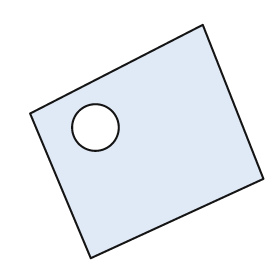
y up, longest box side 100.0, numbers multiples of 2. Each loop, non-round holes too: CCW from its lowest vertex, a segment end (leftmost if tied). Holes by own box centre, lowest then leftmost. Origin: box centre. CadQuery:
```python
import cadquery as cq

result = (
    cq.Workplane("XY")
    .moveTo(-24.0, -50.0)
    .lineTo(50.0, -16.0)
    .lineTo(24.0, 50.0)
    .lineTo(-50.0, 12.0)
    .close()
    .moveTo(-22.0, 6.0)
    .circle(10.0)
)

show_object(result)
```